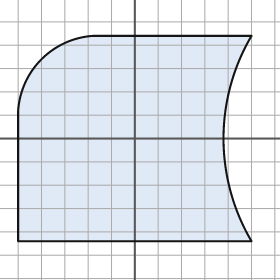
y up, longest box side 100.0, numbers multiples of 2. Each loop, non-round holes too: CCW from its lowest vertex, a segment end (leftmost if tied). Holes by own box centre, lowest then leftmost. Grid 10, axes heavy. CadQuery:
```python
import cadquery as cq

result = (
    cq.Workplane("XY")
    .moveTo(-50.0, -44.0)
    .lineTo(50.0, -44.0)
    .threePointArc((38.0, 0.0), (50.0, 44.0))
    .lineTo(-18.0, 44.0)
    .threePointArc((-40.0, 34.0), (-50.0, 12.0))
    .close()
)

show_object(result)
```